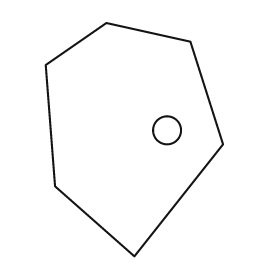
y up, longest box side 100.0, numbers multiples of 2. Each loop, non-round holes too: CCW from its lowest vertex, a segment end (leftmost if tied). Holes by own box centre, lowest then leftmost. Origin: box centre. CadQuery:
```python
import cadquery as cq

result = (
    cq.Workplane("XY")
    .moveTo(0.0, -50.0)
    .lineTo(38.0, -2.0)
    .lineTo(24.0, 42.0)
    .lineTo(-12.0, 50.0)
    .lineTo(-38.0, 32.0)
    .lineTo(-34.0, -20.0)
    .close()
    .moveTo(14.0, 4.0)
    .circle(6.0)
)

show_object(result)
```